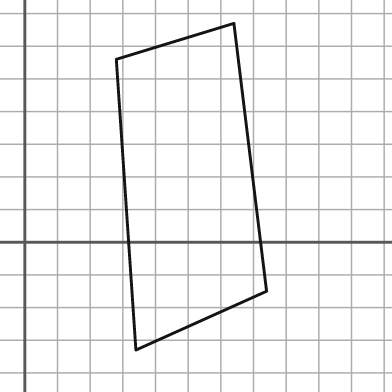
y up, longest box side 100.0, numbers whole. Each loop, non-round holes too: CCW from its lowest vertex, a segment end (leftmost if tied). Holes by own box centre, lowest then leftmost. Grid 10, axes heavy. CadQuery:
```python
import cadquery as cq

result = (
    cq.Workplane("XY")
    .moveTo(34.0, -33.0)
    .lineTo(74.0, -15.0)
    .lineTo(64.0, 67.0)
    .lineTo(28.0, 56.0)
    .close()
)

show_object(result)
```